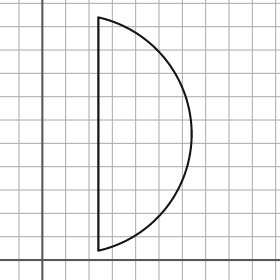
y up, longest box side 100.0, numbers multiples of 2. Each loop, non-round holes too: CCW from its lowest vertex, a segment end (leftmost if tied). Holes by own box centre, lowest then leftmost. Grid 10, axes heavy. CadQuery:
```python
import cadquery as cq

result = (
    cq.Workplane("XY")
    .moveTo(24.0, 4.0)
    .threePointArc((64.0, 54.0), (24.0, 104.0))
    .close()
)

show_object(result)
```